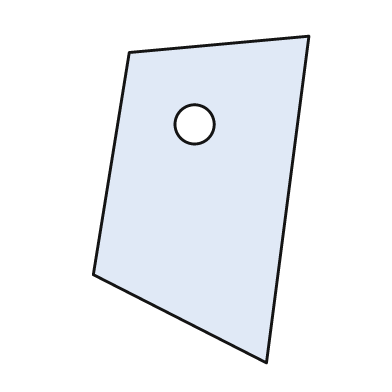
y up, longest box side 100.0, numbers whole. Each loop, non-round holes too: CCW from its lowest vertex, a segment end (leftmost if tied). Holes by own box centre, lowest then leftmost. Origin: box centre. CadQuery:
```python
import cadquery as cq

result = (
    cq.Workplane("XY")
    .moveTo(20.0, -50.0)
    .lineTo(33.0, 50.0)
    .lineTo(-22.0, 45.0)
    .lineTo(-33.0, -23.0)
    .close()
    .moveTo(-2.0, 23.0)
    .circle(6.0)
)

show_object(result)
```